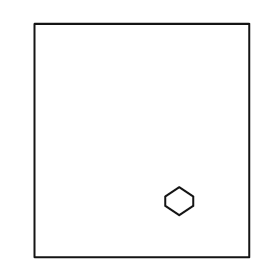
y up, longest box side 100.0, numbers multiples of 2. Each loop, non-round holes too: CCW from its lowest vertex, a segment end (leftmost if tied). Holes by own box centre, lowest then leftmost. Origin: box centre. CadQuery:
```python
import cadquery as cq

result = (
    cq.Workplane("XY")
    .moveTo(-46.0, -50.0)
    .lineTo(46.0, -50.0)
    .lineTo(46.0, 50.0)
    .lineTo(-46.0, 50.0)
    .close()
    .moveTo(16.0, -32.0)
    .lineTo(22.0, -28.0)
    .lineTo(22.0, -24.0)
    .lineTo(16.0, -20.0)
    .lineTo(10.0, -24.0)
    .lineTo(10.0, -28.0)
    .close()
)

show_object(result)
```